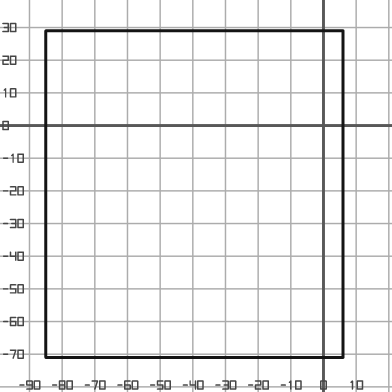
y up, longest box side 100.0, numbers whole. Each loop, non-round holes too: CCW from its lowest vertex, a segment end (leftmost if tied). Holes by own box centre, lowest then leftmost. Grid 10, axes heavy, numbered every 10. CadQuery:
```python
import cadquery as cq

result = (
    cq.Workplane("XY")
    .moveTo(-85.0, -71.0)
    .lineTo(6.0, -71.0)
    .lineTo(6.0, 29.0)
    .lineTo(-85.0, 29.0)
    .close()
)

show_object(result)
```